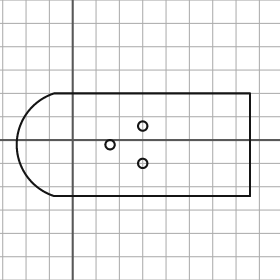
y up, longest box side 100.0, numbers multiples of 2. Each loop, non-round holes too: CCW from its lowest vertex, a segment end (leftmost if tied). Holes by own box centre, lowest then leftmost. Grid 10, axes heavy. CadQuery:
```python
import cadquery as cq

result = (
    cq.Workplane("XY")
    .moveTo(-8.0, -24.0)
    .lineTo(76.0, -24.0)
    .lineTo(76.0, 20.0)
    .lineTo(-8.0, 20.0)
    .threePointArc((-24.0, -2.0), (-8.0, -24.0))
    .close()
    .moveTo(30.0, -10.0)
    .circle(2.0)
    .moveTo(16.0, -2.0)
    .circle(2.0)
    .moveTo(30.0, 6.0)
    .circle(2.0)
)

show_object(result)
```